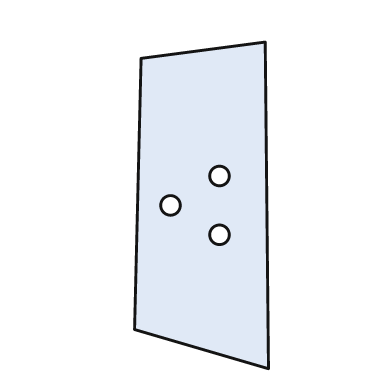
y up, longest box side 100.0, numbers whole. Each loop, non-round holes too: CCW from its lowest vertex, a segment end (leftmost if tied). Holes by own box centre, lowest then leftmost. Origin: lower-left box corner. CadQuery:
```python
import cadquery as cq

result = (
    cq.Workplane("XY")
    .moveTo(41.0, 0.0)
    .lineTo(40.0, 100.0)
    .lineTo(2.0, 95.0)
    .lineTo(0.0, 12.0)
    .close()
    .moveTo(26.0, 41.0)
    .circle(3.0)
    .moveTo(11.0, 50.0)
    .circle(3.0)
    .moveTo(26.0, 59.0)
    .circle(3.0)
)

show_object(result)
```